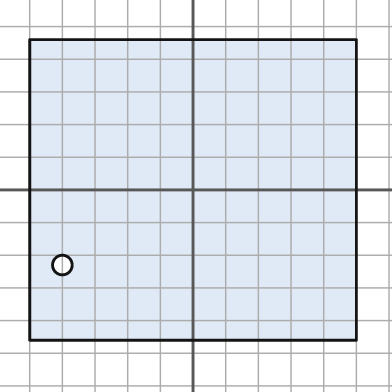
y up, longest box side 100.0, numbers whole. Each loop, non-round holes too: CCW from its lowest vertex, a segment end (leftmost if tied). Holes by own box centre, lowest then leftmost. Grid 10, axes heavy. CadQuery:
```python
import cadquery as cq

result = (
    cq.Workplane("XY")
    .moveTo(-50.0, -46.0)
    .lineTo(50.0, -46.0)
    .lineTo(50.0, 46.0)
    .lineTo(-50.0, 46.0)
    .close()
    .moveTo(-40.0, -23.0)
    .circle(3.0)
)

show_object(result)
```